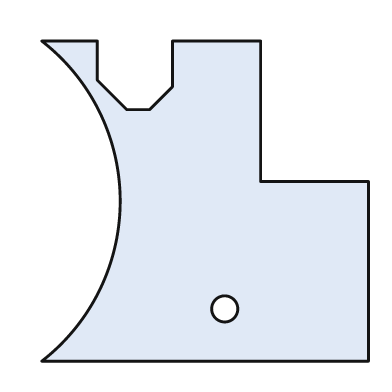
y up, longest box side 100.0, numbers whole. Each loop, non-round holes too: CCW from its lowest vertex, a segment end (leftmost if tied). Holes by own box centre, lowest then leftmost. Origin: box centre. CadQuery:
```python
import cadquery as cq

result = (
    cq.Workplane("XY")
    .moveTo(-50.0, -49.0)
    .lineTo(50.0, -49.0)
    .lineTo(50.0, 6.0)
    .lineTo(17.0, 6.0)
    .lineTo(17.0, 49.0)
    .lineTo(-10.0, 49.0)
    .lineTo(-10.0, 35.0)
    .lineTo(-17.0, 28.0)
    .lineTo(-24.0, 28.0)
    .lineTo(-33.0, 37.0)
    .lineTo(-33.0, 49.0)
    .lineTo(-50.0, 49.0)
    .threePointArc((-26.0, 0.0), (-50.0, -49.0))
    .close()
    .moveTo(6.0, -33.0)
    .circle(4.0)
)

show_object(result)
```